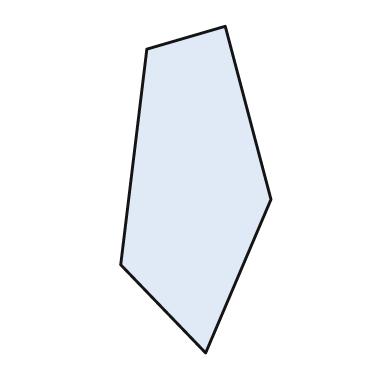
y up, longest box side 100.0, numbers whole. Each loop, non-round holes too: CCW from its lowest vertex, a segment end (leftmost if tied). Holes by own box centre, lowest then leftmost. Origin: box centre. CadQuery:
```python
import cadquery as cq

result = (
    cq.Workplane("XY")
    .moveTo(3.0, -50.0)
    .lineTo(23.0, -3.0)
    .lineTo(9.0, 50.0)
    .lineTo(-15.0, 43.0)
    .lineTo(-23.0, -23.0)
    .close()
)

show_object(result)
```